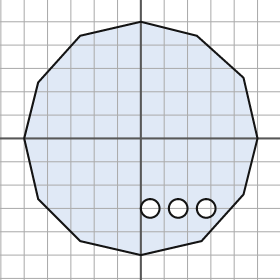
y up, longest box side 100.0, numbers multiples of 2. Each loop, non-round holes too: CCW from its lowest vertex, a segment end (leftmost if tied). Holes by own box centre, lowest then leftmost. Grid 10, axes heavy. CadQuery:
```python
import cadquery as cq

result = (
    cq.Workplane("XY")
    .moveTo(0.0, -50.0)
    .lineTo(26.0, -44.0)
    .lineTo(44.0, -24.0)
    .lineTo(50.0, 0.0)
    .lineTo(44.0, 26.0)
    .lineTo(24.0, 44.0)
    .lineTo(0.0, 50.0)
    .lineTo(-26.0, 44.0)
    .lineTo(-44.0, 24.0)
    .lineTo(-50.0, 0.0)
    .lineTo(-44.0, -26.0)
    .lineTo(-26.0, -44.0)
    .close()
    .moveTo(4.0, -30.0)
    .circle(4.0)
    .moveTo(16.0, -30.0)
    .circle(4.0)
    .moveTo(28.0, -30.0)
    .circle(4.0)
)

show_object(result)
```